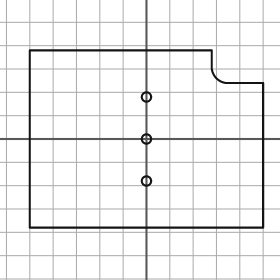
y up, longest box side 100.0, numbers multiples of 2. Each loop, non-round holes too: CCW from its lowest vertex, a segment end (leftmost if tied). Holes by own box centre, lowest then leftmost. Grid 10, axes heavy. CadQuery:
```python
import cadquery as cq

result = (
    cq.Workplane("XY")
    .moveTo(-50.0, -38.0)
    .lineTo(50.0, -38.0)
    .lineTo(50.0, 24.0)
    .lineTo(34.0, 24.0)
    .threePointArc((30.0, 26.0), (28.0, 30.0))
    .lineTo(28.0, 38.0)
    .lineTo(-50.0, 38.0)
    .close()
    .moveTo(0.0, -18.0)
    .circle(2.0)
    .moveTo(0.0, 0.0)
    .circle(2.0)
    .moveTo(0.0, 18.0)
    .circle(2.0)
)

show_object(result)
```